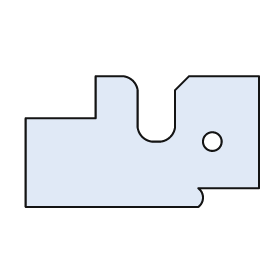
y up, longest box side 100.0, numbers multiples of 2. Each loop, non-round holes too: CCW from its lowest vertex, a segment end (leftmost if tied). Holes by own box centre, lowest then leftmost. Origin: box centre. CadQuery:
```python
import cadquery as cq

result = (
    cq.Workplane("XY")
    .moveTo(-50.0, -28.0)
    .lineTo(24.0, -28.0)
    .threePointArc((26.0, -24.0), (24.0, -20.0))
    .lineTo(50.0, -20.0)
    .lineTo(50.0, 28.0)
    .lineTo(20.0, 28.0)
    .lineTo(14.0, 22.0)
    .lineTo(14.0, 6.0)
    .threePointArc((12.0, 2.0), (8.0, 0.0))
    .lineTo(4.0, 0.0)
    .threePointArc((0.0, 2.0), (-2.0, 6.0))
    .lineTo(-2.0, 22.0)
    .threePointArc((-4.0, 26.0), (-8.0, 28.0))
    .lineTo(-20.0, 28.0)
    .lineTo(-20.0, 10.0)
    .lineTo(-50.0, 10.0)
    .close()
    .moveTo(30.0, 0.0)
    .circle(4.0)
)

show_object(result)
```